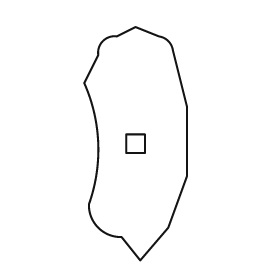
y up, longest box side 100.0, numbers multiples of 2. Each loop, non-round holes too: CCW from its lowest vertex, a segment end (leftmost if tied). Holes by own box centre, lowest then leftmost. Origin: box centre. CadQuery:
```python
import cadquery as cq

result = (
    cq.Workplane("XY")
    .moveTo(2.0, -50.0)
    .lineTo(14.0, -36.0)
    .lineTo(22.0, -14.0)
    .lineTo(22.0, 16.0)
    .lineTo(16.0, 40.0)
    .threePointArc((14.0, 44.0), (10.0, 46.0))
    .lineTo(0.0, 50.0)
    .lineTo(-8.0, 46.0)
    .threePointArc((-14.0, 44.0), (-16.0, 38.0))
    .lineTo(-22.0, 26.0)
    .threePointArc((-16.0, 0.0), (-20.0, -26.0))
    .threePointArc((-16.0, -36.0), (-6.0, -40.0))
    .close()
    .moveTo(-4.0, -4.0)
    .lineTo(4.0, -4.0)
    .lineTo(4.0, 4.0)
    .lineTo(-4.0, 4.0)
    .close()
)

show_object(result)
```